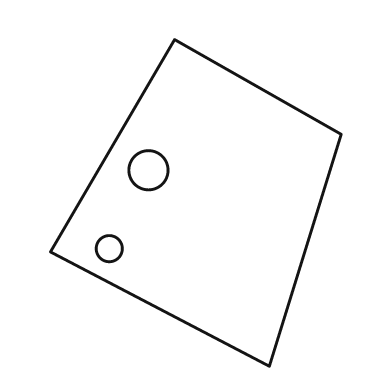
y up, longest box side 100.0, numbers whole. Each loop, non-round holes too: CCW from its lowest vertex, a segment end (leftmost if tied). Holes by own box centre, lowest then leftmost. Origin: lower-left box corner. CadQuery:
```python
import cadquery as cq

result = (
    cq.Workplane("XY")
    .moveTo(67.0, 0.0)
    .lineTo(89.0, 71.0)
    .lineTo(38.0, 100.0)
    .lineTo(0.0, 35.0)
    .close()
    .moveTo(18.0, 36.0)
    .circle(4.0)
    .moveTo(30.0, 60.0)
    .circle(6.0)
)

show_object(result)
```